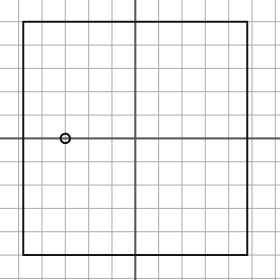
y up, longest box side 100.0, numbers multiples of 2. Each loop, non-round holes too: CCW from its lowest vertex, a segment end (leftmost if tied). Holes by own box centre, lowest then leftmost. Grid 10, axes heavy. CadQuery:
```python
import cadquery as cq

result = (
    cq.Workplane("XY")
    .moveTo(-48.0, -50.0)
    .lineTo(48.0, -50.0)
    .lineTo(48.0, 50.0)
    .lineTo(-48.0, 50.0)
    .close()
    .moveTo(-30.0, 0.0)
    .circle(2.0)
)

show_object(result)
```